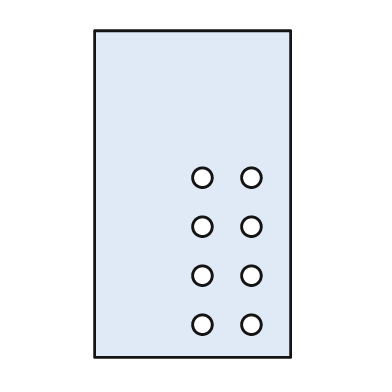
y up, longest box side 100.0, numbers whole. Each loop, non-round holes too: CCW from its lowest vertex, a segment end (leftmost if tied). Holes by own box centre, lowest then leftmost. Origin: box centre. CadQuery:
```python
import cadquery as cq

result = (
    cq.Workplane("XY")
    .moveTo(-30.0, -50.0)
    .lineTo(30.0, -50.0)
    .lineTo(30.0, 50.0)
    .lineTo(-30.0, 50.0)
    .close()
    .moveTo(3.0, -40.0)
    .circle(3.0)
    .moveTo(18.0, -40.0)
    .circle(3.0)
    .moveTo(3.0, -25.0)
    .circle(3.0)
    .moveTo(18.0, -25.0)
    .circle(3.0)
    .moveTo(3.0, -10.0)
    .circle(3.0)
    .moveTo(18.0, -10.0)
    .circle(3.0)
    .moveTo(3.0, 5.0)
    .circle(3.0)
    .moveTo(18.0, 5.0)
    .circle(3.0)
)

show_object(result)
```